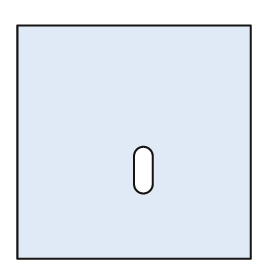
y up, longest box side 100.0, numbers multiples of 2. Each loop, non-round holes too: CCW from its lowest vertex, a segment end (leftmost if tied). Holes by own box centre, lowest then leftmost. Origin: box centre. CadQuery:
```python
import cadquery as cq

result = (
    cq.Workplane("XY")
    .moveTo(-50.0, -50.0)
    .lineTo(50.0, -50.0)
    .lineTo(50.0, 50.0)
    .lineTo(-50.0, 50.0)
    .close()
    .moveTo(0.0, -18.0)
    .threePointArc((4.0, -22.0), (8.0, -18.0))
    .lineTo(8.0, -6.0)
    .threePointArc((4.0, -2.0), (0.0, -6.0))
    .close()
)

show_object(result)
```